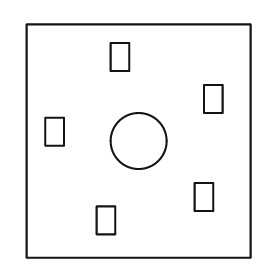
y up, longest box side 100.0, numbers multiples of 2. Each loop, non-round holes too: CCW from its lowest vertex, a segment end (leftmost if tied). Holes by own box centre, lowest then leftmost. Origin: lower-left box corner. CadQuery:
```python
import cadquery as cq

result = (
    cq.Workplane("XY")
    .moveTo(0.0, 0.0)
    .lineTo(96.0, 0.0)
    .lineTo(96.0, 100.0)
    .lineTo(0.0, 100.0)
    .close()
    .moveTo(30.0, 10.0)
    .lineTo(38.0, 10.0)
    .lineTo(38.0, 22.0)
    .lineTo(30.0, 22.0)
    .close()
    .moveTo(72.0, 20.0)
    .lineTo(80.0, 20.0)
    .lineTo(80.0, 32.0)
    .lineTo(72.0, 32.0)
    .close()
    .moveTo(48.0, 50.0)
    .circle(12.0)
    .moveTo(8.0, 48.0)
    .lineTo(16.0, 48.0)
    .lineTo(16.0, 60.0)
    .lineTo(8.0, 60.0)
    .close()
    .moveTo(76.0, 62.0)
    .lineTo(84.0, 62.0)
    .lineTo(84.0, 74.0)
    .lineTo(76.0, 74.0)
    .close()
    .moveTo(36.0, 80.0)
    .lineTo(44.0, 80.0)
    .lineTo(44.0, 92.0)
    .lineTo(36.0, 92.0)
    .close()
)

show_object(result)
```